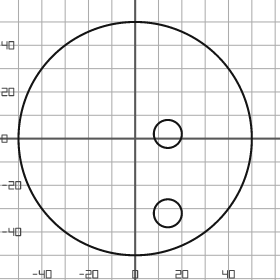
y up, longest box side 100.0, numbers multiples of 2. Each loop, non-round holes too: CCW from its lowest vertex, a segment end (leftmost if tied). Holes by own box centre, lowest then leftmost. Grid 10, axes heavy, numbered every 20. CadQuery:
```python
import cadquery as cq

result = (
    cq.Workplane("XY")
    .moveTo(0.0, 0.0)
    .circle(50.0)
    .moveTo(14.0, -32.0)
    .circle(6.0)
    .moveTo(14.0, 2.0)
    .circle(6.0)
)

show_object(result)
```